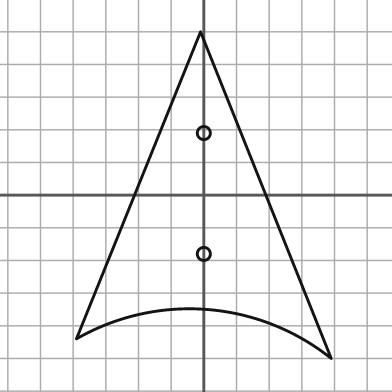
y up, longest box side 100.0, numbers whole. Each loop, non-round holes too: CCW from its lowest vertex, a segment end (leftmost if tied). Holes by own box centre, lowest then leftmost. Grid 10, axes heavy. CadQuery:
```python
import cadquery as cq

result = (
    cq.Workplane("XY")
    .moveTo(39.0, -50.0)
    .lineTo(-1.0, 50.0)
    .lineTo(-39.0, -44.0)
    .threePointArc((1.0, -35.0), (39.0, -50.0))
    .close()
    .moveTo(0.0, -18.0)
    .circle(2.0)
    .moveTo(0.0, 19.0)
    .circle(2.0)
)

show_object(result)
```